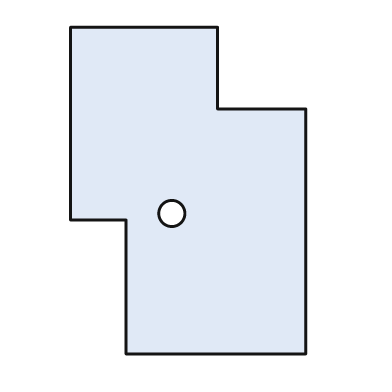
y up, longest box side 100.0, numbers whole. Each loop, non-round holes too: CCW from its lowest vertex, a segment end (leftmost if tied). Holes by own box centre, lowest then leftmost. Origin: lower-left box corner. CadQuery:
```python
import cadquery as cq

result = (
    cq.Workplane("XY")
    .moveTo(17.0, 0.0)
    .lineTo(72.0, 0.0)
    .lineTo(72.0, 75.0)
    .lineTo(45.0, 75.0)
    .lineTo(45.0, 100.0)
    .lineTo(0.0, 100.0)
    .lineTo(0.0, 41.0)
    .lineTo(17.0, 41.0)
    .close()
    .moveTo(31.0, 43.0)
    .circle(4.0)
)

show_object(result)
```